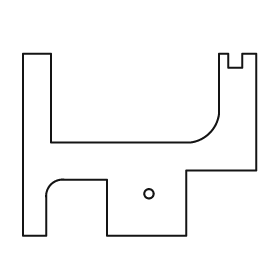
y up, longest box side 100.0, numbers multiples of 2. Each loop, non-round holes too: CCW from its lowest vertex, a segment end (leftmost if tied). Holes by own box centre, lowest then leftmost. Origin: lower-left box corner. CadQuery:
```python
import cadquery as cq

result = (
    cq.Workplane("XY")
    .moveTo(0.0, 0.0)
    .lineTo(10.0, 0.0)
    .lineTo(10.0, 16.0)
    .threePointArc((12.0, 22.0), (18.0, 24.0))
    .lineTo(36.0, 24.0)
    .lineTo(36.0, 0.0)
    .lineTo(70.0, 0.0)
    .lineTo(70.0, 28.0)
    .lineTo(100.0, 28.0)
    .lineTo(100.0, 78.0)
    .lineTo(94.0, 78.0)
    .lineTo(94.0, 72.0)
    .lineTo(88.0, 72.0)
    .lineTo(88.0, 78.0)
    .lineTo(84.0, 78.0)
    .lineTo(84.0, 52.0)
    .threePointArc((80.0, 44.0), (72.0, 40.0))
    .lineTo(12.0, 40.0)
    .lineTo(12.0, 78.0)
    .lineTo(0.0, 78.0)
    .close()
    .moveTo(54.0, 18.0)
    .circle(2.0)
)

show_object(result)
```